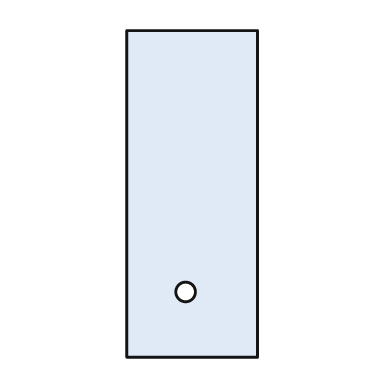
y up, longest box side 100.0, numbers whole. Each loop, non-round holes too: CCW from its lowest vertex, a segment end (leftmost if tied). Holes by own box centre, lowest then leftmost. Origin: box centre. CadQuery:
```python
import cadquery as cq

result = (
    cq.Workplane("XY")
    .moveTo(-20.0, -50.0)
    .lineTo(20.0, -50.0)
    .lineTo(20.0, 50.0)
    .lineTo(-20.0, 50.0)
    .close()
    .moveTo(-2.0, -30.0)
    .circle(3.0)
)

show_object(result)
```